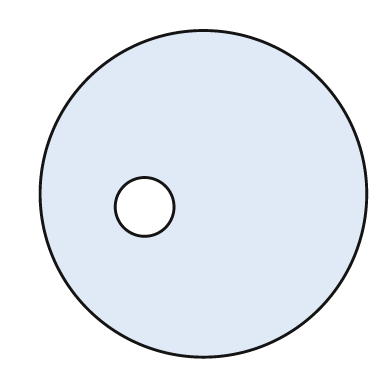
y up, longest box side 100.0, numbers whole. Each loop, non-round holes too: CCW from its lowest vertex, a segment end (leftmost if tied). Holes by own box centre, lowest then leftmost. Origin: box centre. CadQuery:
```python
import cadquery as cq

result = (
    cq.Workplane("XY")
    .moveTo(0.0, 0.0)
    .circle(50.0)
    .moveTo(-18.0, -4.0)
    .circle(9.0)
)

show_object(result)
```